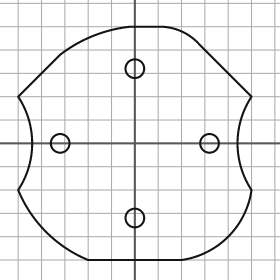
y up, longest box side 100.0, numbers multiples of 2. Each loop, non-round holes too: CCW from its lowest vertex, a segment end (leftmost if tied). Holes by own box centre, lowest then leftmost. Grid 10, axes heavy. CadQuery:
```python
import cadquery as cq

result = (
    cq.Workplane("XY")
    .moveTo(-20.0, -50.0)
    .lineTo(20.0, -50.0)
    .threePointArc((40.0, -40.0), (50.0, -20.0))
    .threePointArc((44.0, 0.0), (50.0, 20.0))
    .lineTo(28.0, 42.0)
    .threePointArc((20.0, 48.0), (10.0, 50.0))
    .lineTo(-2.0, 50.0)
    .threePointArc((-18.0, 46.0), (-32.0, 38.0))
    .lineTo(-50.0, 20.0)
    .threePointArc((-44.0, 0.0), (-50.0, -20.0))
    .threePointArc((-38.0, -38.0), (-20.0, -50.0))
    .close()
    .moveTo(0.0, -32.0)
    .circle(4.0)
    .moveTo(-32.0, 0.0)
    .circle(4.0)
    .moveTo(32.0, 0.0)
    .circle(4.0)
    .moveTo(0.0, 32.0)
    .circle(4.0)
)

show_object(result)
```